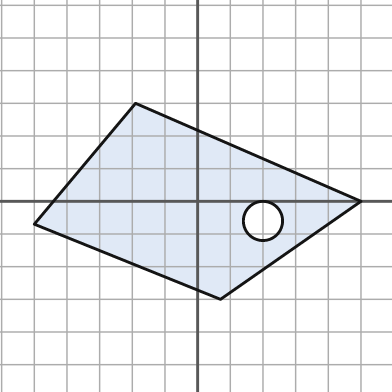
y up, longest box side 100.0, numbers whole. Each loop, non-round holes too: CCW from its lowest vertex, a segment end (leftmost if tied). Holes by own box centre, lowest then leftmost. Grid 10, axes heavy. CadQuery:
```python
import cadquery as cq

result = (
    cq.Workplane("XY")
    .moveTo(7.0, -30.0)
    .lineTo(50.0, 0.0)
    .lineTo(-19.0, 30.0)
    .lineTo(-50.0, -7.0)
    .close()
    .moveTo(20.0, -6.0)
    .circle(6.0)
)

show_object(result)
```